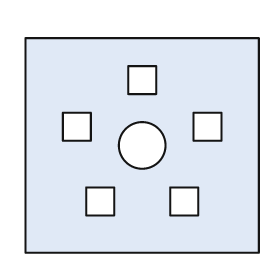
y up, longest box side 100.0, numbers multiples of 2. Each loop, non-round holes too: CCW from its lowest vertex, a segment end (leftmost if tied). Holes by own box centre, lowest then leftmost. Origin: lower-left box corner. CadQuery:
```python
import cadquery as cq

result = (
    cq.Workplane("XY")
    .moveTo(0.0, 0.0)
    .lineTo(100.0, 0.0)
    .lineTo(100.0, 92.0)
    .lineTo(0.0, 92.0)
    .close()
    .moveTo(26.0, 16.0)
    .lineTo(38.0, 16.0)
    .lineTo(38.0, 28.0)
    .lineTo(26.0, 28.0)
    .close()
    .moveTo(62.0, 16.0)
    .lineTo(74.0, 16.0)
    .lineTo(74.0, 28.0)
    .lineTo(62.0, 28.0)
    .close()
    .moveTo(50.0, 46.0)
    .circle(10.0)
    .moveTo(16.0, 48.0)
    .lineTo(28.0, 48.0)
    .lineTo(28.0, 60.0)
    .lineTo(16.0, 60.0)
    .close()
    .moveTo(72.0, 48.0)
    .lineTo(84.0, 48.0)
    .lineTo(84.0, 60.0)
    .lineTo(72.0, 60.0)
    .close()
    .moveTo(44.0, 68.0)
    .lineTo(56.0, 68.0)
    .lineTo(56.0, 80.0)
    .lineTo(44.0, 80.0)
    .close()
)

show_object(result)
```